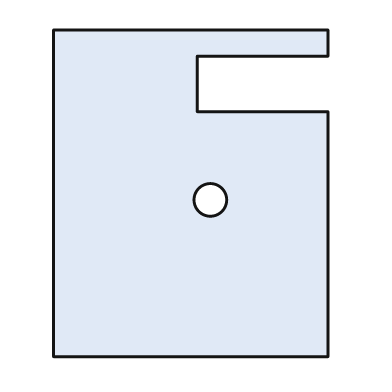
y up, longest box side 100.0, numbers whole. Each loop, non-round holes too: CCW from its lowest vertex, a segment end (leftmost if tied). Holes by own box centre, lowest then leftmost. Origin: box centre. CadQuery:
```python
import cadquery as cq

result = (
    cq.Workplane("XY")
    .moveTo(-42.0, -50.0)
    .lineTo(42.0, -50.0)
    .lineTo(42.0, 25.0)
    .lineTo(2.0, 25.0)
    .lineTo(2.0, 42.0)
    .lineTo(42.0, 42.0)
    .lineTo(42.0, 50.0)
    .lineTo(-42.0, 50.0)
    .close()
    .moveTo(6.0, -2.0)
    .circle(5.0)
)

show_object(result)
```